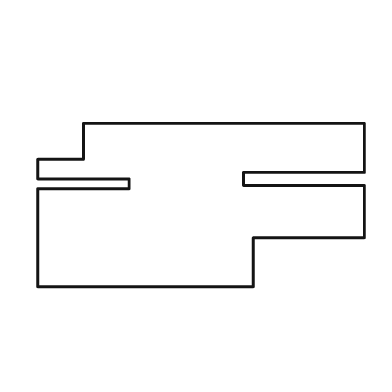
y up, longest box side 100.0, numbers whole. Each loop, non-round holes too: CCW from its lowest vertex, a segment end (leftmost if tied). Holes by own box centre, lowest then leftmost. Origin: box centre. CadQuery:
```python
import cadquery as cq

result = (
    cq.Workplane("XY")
    .moveTo(-50.0, -25.0)
    .lineTo(16.0, -25.0)
    .lineTo(16.0, -10.0)
    .lineTo(50.0, -10.0)
    .lineTo(50.0, 6.0)
    .lineTo(13.0, 6.0)
    .lineTo(13.0, 10.0)
    .lineTo(50.0, 10.0)
    .lineTo(50.0, 25.0)
    .lineTo(-36.0, 25.0)
    .lineTo(-36.0, 14.0)
    .lineTo(-50.0, 14.0)
    .lineTo(-50.0, 8.0)
    .lineTo(-22.0, 8.0)
    .lineTo(-22.0, 5.0)
    .lineTo(-50.0, 5.0)
    .close()
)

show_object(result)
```